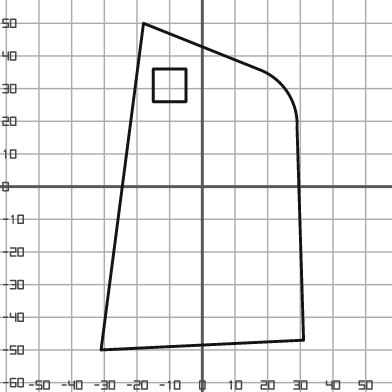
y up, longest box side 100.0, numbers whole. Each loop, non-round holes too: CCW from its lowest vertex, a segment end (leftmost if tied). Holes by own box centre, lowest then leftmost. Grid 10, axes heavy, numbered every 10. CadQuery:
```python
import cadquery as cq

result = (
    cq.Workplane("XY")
    .moveTo(-31.0, -50.0)
    .lineTo(31.0, -47.0)
    .lineTo(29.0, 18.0)
    .threePointArc((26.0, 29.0), (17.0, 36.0))
    .lineTo(-18.0, 50.0)
    .close()
    .moveTo(-15.0, 26.0)
    .lineTo(-5.0, 26.0)
    .lineTo(-5.0, 36.0)
    .lineTo(-15.0, 36.0)
    .close()
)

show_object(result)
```